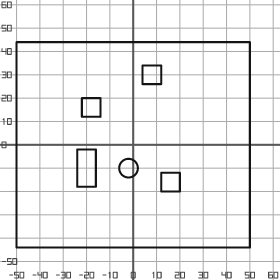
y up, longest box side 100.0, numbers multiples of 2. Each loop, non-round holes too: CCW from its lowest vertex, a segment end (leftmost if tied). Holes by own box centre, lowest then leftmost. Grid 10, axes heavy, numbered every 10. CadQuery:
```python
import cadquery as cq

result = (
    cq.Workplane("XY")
    .moveTo(-50.0, -44.0)
    .lineTo(50.0, -44.0)
    .lineTo(50.0, 44.0)
    .lineTo(-50.0, 44.0)
    .close()
    .moveTo(12.0, -20.0)
    .lineTo(20.0, -20.0)
    .lineTo(20.0, -12.0)
    .lineTo(12.0, -12.0)
    .close()
    .moveTo(-24.0, -18.0)
    .lineTo(-16.0, -18.0)
    .lineTo(-16.0, -2.0)
    .lineTo(-24.0, -2.0)
    .close()
    .moveTo(-2.0, -10.0)
    .circle(4.0)
    .moveTo(-22.0, 12.0)
    .lineTo(-14.0, 12.0)
    .lineTo(-14.0, 20.0)
    .lineTo(-22.0, 20.0)
    .close()
    .moveTo(4.0, 26.0)
    .lineTo(12.0, 26.0)
    .lineTo(12.0, 34.0)
    .lineTo(4.0, 34.0)
    .close()
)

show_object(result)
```